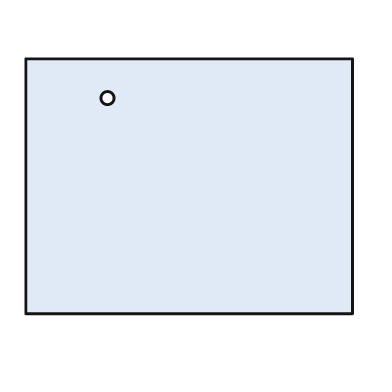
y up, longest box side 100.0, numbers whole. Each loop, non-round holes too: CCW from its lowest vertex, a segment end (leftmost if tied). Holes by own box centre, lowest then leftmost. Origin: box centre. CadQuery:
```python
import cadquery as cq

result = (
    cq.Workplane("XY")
    .moveTo(-50.0, -39.0)
    .lineTo(50.0, -39.0)
    .lineTo(50.0, 39.0)
    .lineTo(-50.0, 39.0)
    .close()
    .moveTo(-25.0, 27.0)
    .circle(2.0)
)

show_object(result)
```